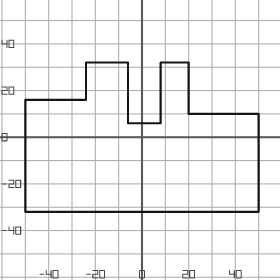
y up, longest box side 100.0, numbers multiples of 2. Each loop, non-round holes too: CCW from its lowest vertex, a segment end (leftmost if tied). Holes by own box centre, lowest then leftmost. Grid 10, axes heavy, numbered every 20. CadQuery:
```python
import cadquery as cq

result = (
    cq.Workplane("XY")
    .moveTo(-50.0, -32.0)
    .lineTo(50.0, -32.0)
    .lineTo(50.0, 10.0)
    .lineTo(20.0, 10.0)
    .lineTo(20.0, 32.0)
    .lineTo(8.0, 32.0)
    .lineTo(8.0, 6.0)
    .lineTo(-6.0, 6.0)
    .lineTo(-6.0, 32.0)
    .lineTo(-24.0, 32.0)
    .lineTo(-24.0, 16.0)
    .lineTo(-50.0, 16.0)
    .close()
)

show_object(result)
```